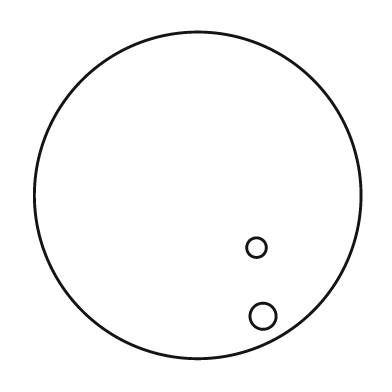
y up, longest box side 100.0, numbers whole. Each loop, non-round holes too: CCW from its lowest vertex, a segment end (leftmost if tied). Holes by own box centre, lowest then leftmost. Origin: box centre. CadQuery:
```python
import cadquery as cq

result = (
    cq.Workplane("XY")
    .moveTo(0.0, 0.0)
    .circle(50.0)
    .moveTo(20.0, -37.0)
    .circle(4.0)
    .moveTo(18.0, -16.0)
    .circle(3.0)
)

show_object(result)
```